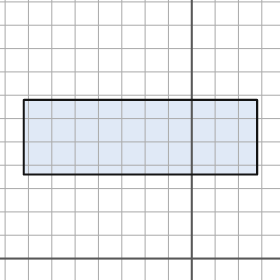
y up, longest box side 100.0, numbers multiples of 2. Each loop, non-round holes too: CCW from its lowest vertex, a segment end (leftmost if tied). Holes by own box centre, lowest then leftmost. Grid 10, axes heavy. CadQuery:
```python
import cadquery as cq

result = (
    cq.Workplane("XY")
    .moveTo(-72.0, 36.0)
    .lineTo(28.0, 36.0)
    .lineTo(28.0, 68.0)
    .lineTo(-72.0, 68.0)
    .close()
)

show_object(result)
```